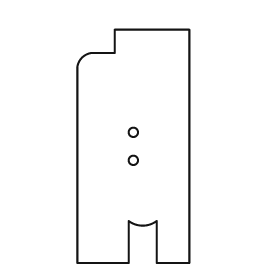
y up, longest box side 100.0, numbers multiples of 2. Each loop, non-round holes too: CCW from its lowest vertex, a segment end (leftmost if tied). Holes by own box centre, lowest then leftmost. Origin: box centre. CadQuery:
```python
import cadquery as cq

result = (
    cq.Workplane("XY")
    .moveTo(-24.0, -50.0)
    .lineTo(-2.0, -50.0)
    .lineTo(-2.0, -32.0)
    .threePointArc((4.0, -34.0), (10.0, -32.0))
    .lineTo(10.0, -50.0)
    .lineTo(24.0, -50.0)
    .lineTo(24.0, 50.0)
    .lineTo(-8.0, 50.0)
    .lineTo(-8.0, 40.0)
    .lineTo(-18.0, 40.0)
    .threePointArc((-22.0, 38.0), (-24.0, 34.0))
    .close()
    .moveTo(0.0, -6.0)
    .circle(2.0)
    .moveTo(0.0, 6.0)
    .circle(2.0)
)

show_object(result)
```